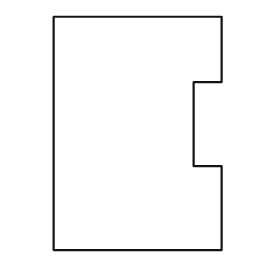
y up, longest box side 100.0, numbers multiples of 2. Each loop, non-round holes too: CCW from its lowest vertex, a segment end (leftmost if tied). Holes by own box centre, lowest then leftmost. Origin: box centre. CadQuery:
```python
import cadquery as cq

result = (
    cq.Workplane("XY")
    .moveTo(-36.0, -50.0)
    .lineTo(36.0, -50.0)
    .lineTo(36.0, -14.0)
    .lineTo(24.0, -14.0)
    .lineTo(24.0, 22.0)
    .lineTo(36.0, 22.0)
    .lineTo(36.0, 50.0)
    .lineTo(-36.0, 50.0)
    .close()
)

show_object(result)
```